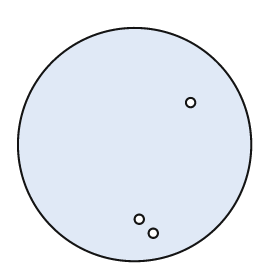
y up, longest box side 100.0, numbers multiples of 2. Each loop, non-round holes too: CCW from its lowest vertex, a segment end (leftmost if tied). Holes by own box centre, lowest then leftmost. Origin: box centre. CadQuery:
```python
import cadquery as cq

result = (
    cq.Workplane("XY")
    .moveTo(0.0, 0.0)
    .circle(50.0)
    .moveTo(8.0, -38.0)
    .circle(2.0)
    .moveTo(2.0, -32.0)
    .circle(2.0)
    .moveTo(24.0, 18.0)
    .circle(2.0)
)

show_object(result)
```